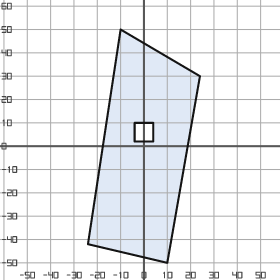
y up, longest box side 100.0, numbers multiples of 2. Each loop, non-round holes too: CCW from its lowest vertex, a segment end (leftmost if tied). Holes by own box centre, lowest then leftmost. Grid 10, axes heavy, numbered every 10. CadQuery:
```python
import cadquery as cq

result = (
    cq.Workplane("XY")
    .moveTo(10.0, -50.0)
    .lineTo(24.0, 30.0)
    .lineTo(-10.0, 50.0)
    .lineTo(-24.0, -42.0)
    .close()
    .moveTo(-4.0, 2.0)
    .lineTo(4.0, 2.0)
    .lineTo(4.0, 10.0)
    .lineTo(-4.0, 10.0)
    .close()
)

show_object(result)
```